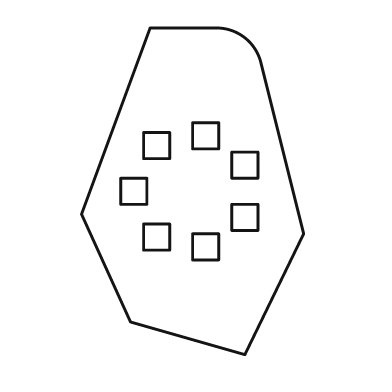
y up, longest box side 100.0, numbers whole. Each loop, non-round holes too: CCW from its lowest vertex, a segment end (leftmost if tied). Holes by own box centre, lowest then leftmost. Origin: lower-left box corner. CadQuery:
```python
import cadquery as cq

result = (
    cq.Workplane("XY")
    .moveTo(50.0, 0.0)
    .lineTo(68.0, 37.0)
    .lineTo(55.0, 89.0)
    .threePointArc((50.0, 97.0), (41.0, 100.0))
    .lineTo(21.0, 100.0)
    .lineTo(0.0, 43.0)
    .lineTo(15.0, 10.0)
    .close()
    .moveTo(34.0, 29.0)
    .lineTo(42.0, 29.0)
    .lineTo(42.0, 37.0)
    .lineTo(34.0, 37.0)
    .close()
    .moveTo(19.0, 32.0)
    .lineTo(27.0, 32.0)
    .lineTo(27.0, 40.0)
    .lineTo(19.0, 40.0)
    .close()
    .moveTo(46.0, 38.0)
    .lineTo(54.0, 38.0)
    .lineTo(54.0, 46.0)
    .lineTo(46.0, 46.0)
    .close()
    .moveTo(12.0, 46.0)
    .lineTo(20.0, 46.0)
    .lineTo(20.0, 54.0)
    .lineTo(12.0, 54.0)
    .close()
    .moveTo(46.0, 54.0)
    .lineTo(54.0, 54.0)
    .lineTo(54.0, 62.0)
    .lineTo(46.0, 62.0)
    .close()
    .moveTo(19.0, 60.0)
    .lineTo(27.0, 60.0)
    .lineTo(27.0, 68.0)
    .lineTo(19.0, 68.0)
    .close()
    .moveTo(34.0, 63.0)
    .lineTo(42.0, 63.0)
    .lineTo(42.0, 71.0)
    .lineTo(34.0, 71.0)
    .close()
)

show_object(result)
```